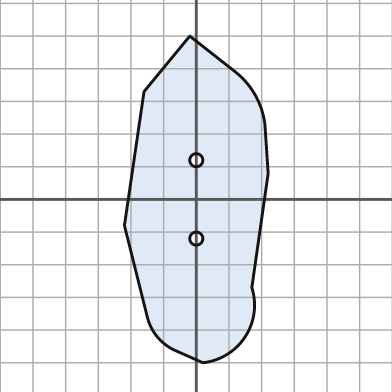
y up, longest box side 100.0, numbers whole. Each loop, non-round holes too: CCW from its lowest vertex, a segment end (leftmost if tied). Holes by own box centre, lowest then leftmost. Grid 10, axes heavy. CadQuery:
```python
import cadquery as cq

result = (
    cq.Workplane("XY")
    .moveTo(2.0, -50.0)
    .threePointArc((15.0, -42.0), (17.0, -27.0))
    .lineTo(22.0, 8.0)
    .lineTo(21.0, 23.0)
    .threePointArc((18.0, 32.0), (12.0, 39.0))
    .lineTo(-2.0, 50.0)
    .lineTo(-16.0, 33.0)
    .lineTo(-22.0, -8.0)
    .lineTo(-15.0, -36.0)
    .threePointArc((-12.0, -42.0), (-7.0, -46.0))
    .close()
    .moveTo(0.0, -12.0)
    .circle(2.0)
    .moveTo(0.0, 12.0)
    .circle(2.0)
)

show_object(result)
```